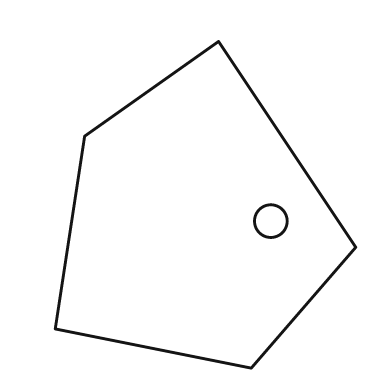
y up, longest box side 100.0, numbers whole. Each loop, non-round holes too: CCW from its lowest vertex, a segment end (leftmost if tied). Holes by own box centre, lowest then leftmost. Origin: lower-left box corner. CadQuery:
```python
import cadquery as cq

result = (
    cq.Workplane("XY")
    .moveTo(60.0, 0.0)
    .lineTo(92.0, 37.0)
    .lineTo(50.0, 100.0)
    .lineTo(9.0, 71.0)
    .lineTo(0.0, 12.0)
    .close()
    .moveTo(66.0, 45.0)
    .circle(5.0)
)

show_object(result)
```